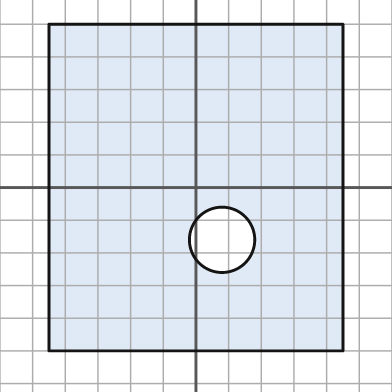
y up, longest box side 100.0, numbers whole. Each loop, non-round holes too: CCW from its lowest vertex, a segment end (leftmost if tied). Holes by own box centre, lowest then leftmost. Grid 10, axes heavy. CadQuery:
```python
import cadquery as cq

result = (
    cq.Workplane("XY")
    .moveTo(-45.0, -50.0)
    .lineTo(45.0, -50.0)
    .lineTo(45.0, 50.0)
    .lineTo(-45.0, 50.0)
    .close()
    .moveTo(8.0, -16.0)
    .circle(10.0)
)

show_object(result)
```